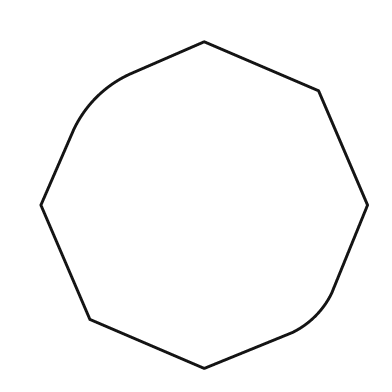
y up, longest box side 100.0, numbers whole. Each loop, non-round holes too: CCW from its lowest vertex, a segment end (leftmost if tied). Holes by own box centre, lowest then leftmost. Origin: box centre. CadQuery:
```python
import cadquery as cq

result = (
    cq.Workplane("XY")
    .moveTo(0.0, -50.0)
    .lineTo(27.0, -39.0)
    .threePointArc((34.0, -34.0), (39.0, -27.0))
    .lineTo(50.0, 0.0)
    .lineTo(35.0, 35.0)
    .lineTo(0.0, 50.0)
    .lineTo(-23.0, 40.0)
    .threePointArc((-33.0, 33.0), (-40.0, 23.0))
    .lineTo(-50.0, 0.0)
    .lineTo(-35.0, -35.0)
    .close()
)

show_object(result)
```